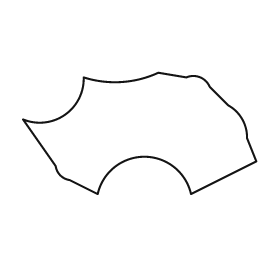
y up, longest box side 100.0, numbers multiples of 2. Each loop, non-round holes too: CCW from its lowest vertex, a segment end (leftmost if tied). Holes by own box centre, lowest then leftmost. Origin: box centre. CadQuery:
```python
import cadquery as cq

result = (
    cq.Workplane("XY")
    .moveTo(-18.0, -26.0)
    .threePointArc((2.0, -10.0), (22.0, -26.0))
    .lineTo(50.0, -12.0)
    .lineTo(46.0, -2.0)
    .threePointArc((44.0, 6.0), (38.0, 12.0))
    .lineTo(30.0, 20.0)
    .threePointArc((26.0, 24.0), (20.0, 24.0))
    .lineTo(8.0, 26.0)
    .threePointArc((-8.0, 22.0), (-24.0, 24.0))
    .threePointArc((-32.0, 8.0), (-50.0, 6.0))
    .lineTo(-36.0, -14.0)
    .threePointArc((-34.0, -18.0), (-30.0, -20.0))
    .close()
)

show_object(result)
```